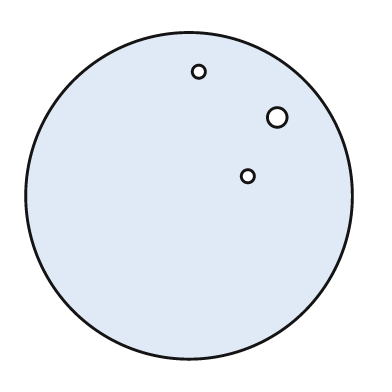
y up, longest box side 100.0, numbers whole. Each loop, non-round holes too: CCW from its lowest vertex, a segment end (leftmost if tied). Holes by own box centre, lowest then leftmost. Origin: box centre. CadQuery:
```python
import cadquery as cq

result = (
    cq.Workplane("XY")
    .moveTo(0.0, 0.0)
    .circle(50.0)
    .moveTo(18.0, 6.0)
    .circle(2.0)
    .moveTo(27.0, 24.0)
    .circle(3.0)
    .moveTo(3.0, 38.0)
    .circle(2.0)
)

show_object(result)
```